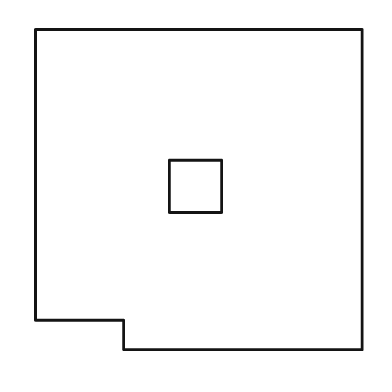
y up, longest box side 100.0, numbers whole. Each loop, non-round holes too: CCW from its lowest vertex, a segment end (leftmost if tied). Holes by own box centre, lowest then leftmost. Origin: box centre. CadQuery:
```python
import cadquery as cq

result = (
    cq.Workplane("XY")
    .moveTo(-23.0, -49.0)
    .lineTo(50.0, -49.0)
    .lineTo(50.0, 49.0)
    .lineTo(-50.0, 49.0)
    .lineTo(-50.0, -40.0)
    .lineTo(-23.0, -40.0)
    .close()
    .moveTo(-9.0, -7.0)
    .lineTo(7.0, -7.0)
    .lineTo(7.0, 9.0)
    .lineTo(-9.0, 9.0)
    .close()
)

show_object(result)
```